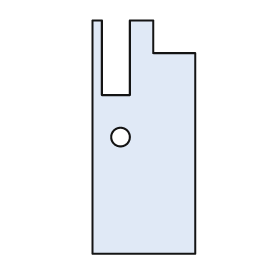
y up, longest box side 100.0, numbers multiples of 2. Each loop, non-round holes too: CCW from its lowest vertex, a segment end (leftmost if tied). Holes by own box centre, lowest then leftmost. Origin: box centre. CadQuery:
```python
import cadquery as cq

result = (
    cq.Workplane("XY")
    .moveTo(-22.0, -50.0)
    .lineTo(22.0, -50.0)
    .lineTo(22.0, 36.0)
    .lineTo(4.0, 36.0)
    .lineTo(4.0, 50.0)
    .lineTo(-6.0, 50.0)
    .lineTo(-6.0, 18.0)
    .lineTo(-18.0, 18.0)
    .lineTo(-18.0, 50.0)
    .lineTo(-22.0, 50.0)
    .close()
    .moveTo(-10.0, 0.0)
    .circle(4.0)
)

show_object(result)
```